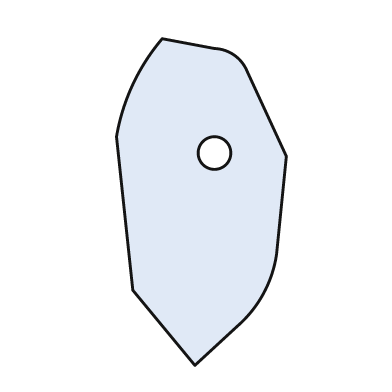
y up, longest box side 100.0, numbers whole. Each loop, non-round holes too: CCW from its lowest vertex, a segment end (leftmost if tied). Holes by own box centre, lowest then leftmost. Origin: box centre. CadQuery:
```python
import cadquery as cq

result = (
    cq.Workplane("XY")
    .moveTo(-2.0, -50.0)
    .lineTo(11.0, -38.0)
    .threePointArc((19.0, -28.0), (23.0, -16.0))
    .lineTo(26.0, 14.0)
    .lineTo(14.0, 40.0)
    .threePointArc((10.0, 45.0), (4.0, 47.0))
    .lineTo(-12.0, 50.0)
    .threePointArc((-21.0, 36.0), (-26.0, 20.0))
    .lineTo(-21.0, -27.0)
    .close()
    .moveTo(4.0, 15.0)
    .circle(5.0)
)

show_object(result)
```